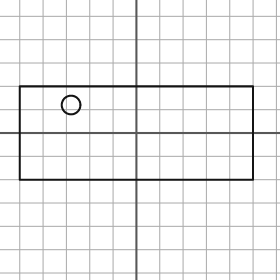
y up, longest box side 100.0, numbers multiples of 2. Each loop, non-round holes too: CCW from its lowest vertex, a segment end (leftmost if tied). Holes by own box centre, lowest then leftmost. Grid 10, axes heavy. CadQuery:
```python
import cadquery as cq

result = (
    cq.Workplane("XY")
    .moveTo(-50.0, -20.0)
    .lineTo(50.0, -20.0)
    .lineTo(50.0, 20.0)
    .lineTo(-50.0, 20.0)
    .close()
    .moveTo(-28.0, 12.0)
    .circle(4.0)
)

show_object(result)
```